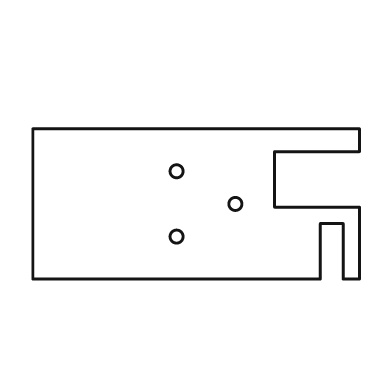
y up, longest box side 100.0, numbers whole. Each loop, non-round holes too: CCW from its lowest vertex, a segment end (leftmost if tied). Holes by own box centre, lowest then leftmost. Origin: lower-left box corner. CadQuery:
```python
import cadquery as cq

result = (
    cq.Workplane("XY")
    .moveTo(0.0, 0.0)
    .lineTo(88.0, 0.0)
    .lineTo(88.0, 17.0)
    .lineTo(95.0, 17.0)
    .lineTo(95.0, 0.0)
    .lineTo(100.0, 0.0)
    .lineTo(100.0, 22.0)
    .lineTo(74.0, 22.0)
    .lineTo(74.0, 39.0)
    .lineTo(100.0, 39.0)
    .lineTo(100.0, 46.0)
    .lineTo(0.0, 46.0)
    .close()
    .moveTo(44.0, 13.0)
    .circle(2.0)
    .moveTo(62.0, 23.0)
    .circle(2.0)
    .moveTo(44.0, 33.0)
    .circle(2.0)
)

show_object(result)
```